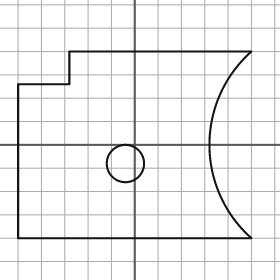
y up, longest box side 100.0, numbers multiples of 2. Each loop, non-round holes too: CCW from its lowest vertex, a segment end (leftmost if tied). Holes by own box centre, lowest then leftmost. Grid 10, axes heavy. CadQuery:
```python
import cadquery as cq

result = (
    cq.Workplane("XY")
    .moveTo(-50.0, -40.0)
    .lineTo(50.0, -40.0)
    .threePointArc((32.0, 0.0), (50.0, 40.0))
    .lineTo(-28.0, 40.0)
    .lineTo(-28.0, 26.0)
    .lineTo(-50.0, 26.0)
    .close()
    .moveTo(-4.0, -8.0)
    .circle(8.0)
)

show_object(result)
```